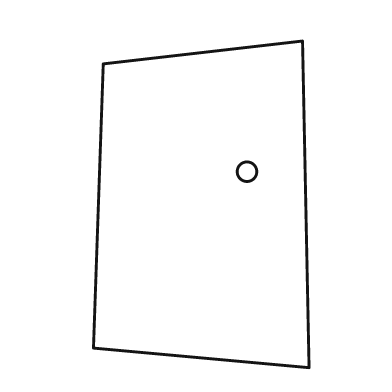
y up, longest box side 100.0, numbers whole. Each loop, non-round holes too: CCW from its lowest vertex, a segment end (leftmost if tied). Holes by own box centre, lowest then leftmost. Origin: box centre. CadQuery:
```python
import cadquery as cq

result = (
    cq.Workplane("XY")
    .moveTo(33.0, -50.0)
    .lineTo(31.0, 50.0)
    .lineTo(-30.0, 43.0)
    .lineTo(-33.0, -44.0)
    .close()
    .moveTo(14.0, 10.0)
    .circle(3.0)
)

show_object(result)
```